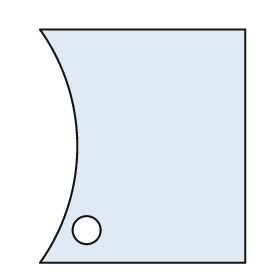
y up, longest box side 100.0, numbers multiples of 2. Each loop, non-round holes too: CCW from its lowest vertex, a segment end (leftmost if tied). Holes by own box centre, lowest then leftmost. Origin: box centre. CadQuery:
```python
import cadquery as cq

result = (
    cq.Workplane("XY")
    .moveTo(-44.0, -50.0)
    .lineTo(44.0, -50.0)
    .lineTo(44.0, 50.0)
    .lineTo(-44.0, 50.0)
    .threePointArc((-28.0, 0.0), (-44.0, -50.0))
    .close()
    .moveTo(-24.0, -36.0)
    .circle(6.0)
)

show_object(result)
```